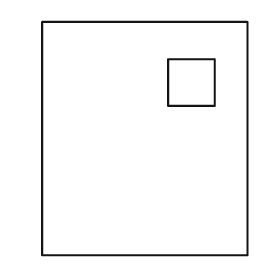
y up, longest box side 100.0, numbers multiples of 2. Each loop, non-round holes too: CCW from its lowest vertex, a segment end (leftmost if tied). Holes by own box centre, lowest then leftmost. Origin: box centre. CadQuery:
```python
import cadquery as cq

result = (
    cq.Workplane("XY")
    .moveTo(-44.0, -50.0)
    .lineTo(44.0, -50.0)
    .lineTo(44.0, 50.0)
    .lineTo(-44.0, 50.0)
    .close()
    .moveTo(10.0, 14.0)
    .lineTo(30.0, 14.0)
    .lineTo(30.0, 34.0)
    .lineTo(10.0, 34.0)
    .close()
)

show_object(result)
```